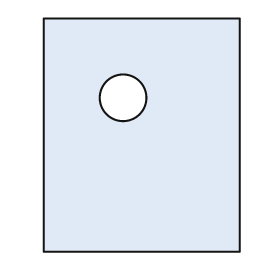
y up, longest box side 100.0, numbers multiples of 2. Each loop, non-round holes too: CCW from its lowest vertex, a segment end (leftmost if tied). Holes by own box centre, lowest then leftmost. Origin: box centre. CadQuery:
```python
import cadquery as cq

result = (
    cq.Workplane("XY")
    .moveTo(-42.0, -50.0)
    .lineTo(42.0, -50.0)
    .lineTo(42.0, 50.0)
    .lineTo(-42.0, 50.0)
    .close()
    .moveTo(-8.0, 16.0)
    .circle(10.0)
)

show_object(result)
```